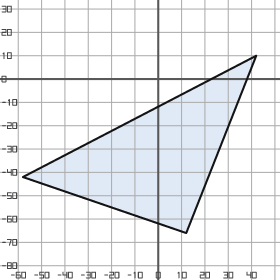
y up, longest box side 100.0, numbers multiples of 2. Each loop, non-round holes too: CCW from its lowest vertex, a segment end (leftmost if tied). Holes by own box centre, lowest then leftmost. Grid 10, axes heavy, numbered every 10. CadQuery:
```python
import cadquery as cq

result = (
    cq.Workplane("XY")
    .moveTo(12.0, -66.0)
    .lineTo(42.0, 10.0)
    .lineTo(-58.0, -42.0)
    .close()
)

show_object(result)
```